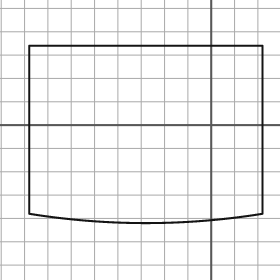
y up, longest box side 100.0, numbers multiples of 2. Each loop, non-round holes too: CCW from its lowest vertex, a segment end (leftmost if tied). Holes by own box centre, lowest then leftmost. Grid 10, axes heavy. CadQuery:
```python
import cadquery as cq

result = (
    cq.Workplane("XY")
    .moveTo(-78.0, -38.0)
    .threePointArc((-28.0, -42.0), (22.0, -38.0))
    .lineTo(22.0, 34.0)
    .lineTo(-78.0, 34.0)
    .close()
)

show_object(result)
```